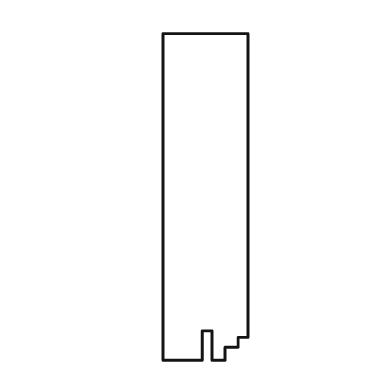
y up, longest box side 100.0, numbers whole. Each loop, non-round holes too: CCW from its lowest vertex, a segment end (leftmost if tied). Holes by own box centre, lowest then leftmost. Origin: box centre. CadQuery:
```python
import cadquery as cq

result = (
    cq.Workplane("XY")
    .moveTo(-13.0, -50.0)
    .lineTo(-1.0, -50.0)
    .lineTo(-1.0, -41.0)
    .lineTo(2.0, -41.0)
    .lineTo(2.0, -50.0)
    .lineTo(6.0, -50.0)
    .lineTo(6.0, -46.0)
    .lineTo(10.0, -46.0)
    .lineTo(10.0, -43.0)
    .lineTo(13.0, -43.0)
    .lineTo(13.0, 50.0)
    .lineTo(-13.0, 50.0)
    .close()
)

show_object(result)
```